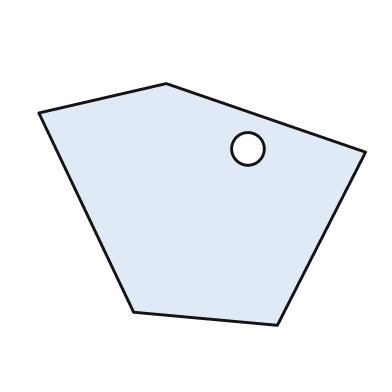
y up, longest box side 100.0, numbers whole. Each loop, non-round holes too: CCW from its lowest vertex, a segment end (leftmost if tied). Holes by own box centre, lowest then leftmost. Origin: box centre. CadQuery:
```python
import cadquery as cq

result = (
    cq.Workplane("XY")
    .moveTo(23.0, -37.0)
    .lineTo(50.0, 16.0)
    .lineTo(-11.0, 37.0)
    .lineTo(-50.0, 28.0)
    .lineTo(-21.0, -33.0)
    .close()
    .moveTo(14.0, 17.0)
    .circle(5.0)
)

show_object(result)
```